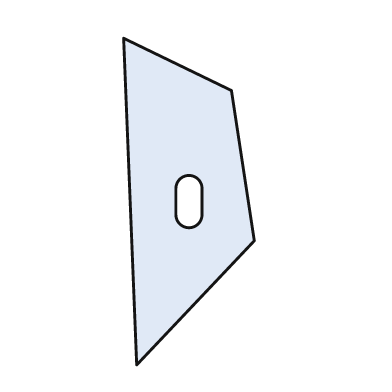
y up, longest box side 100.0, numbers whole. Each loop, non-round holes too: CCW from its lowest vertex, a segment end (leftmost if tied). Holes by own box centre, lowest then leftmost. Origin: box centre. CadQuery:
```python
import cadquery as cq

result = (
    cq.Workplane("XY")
    .moveTo(-16.0, -50.0)
    .lineTo(20.0, -12.0)
    .lineTo(13.0, 34.0)
    .lineTo(-20.0, 50.0)
    .close()
    .moveTo(-4.0, -4.0)
    .threePointArc((0.0, -8.0), (4.0, -4.0))
    .lineTo(4.0, 4.0)
    .threePointArc((0.0, 8.0), (-4.0, 4.0))
    .close()
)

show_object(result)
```